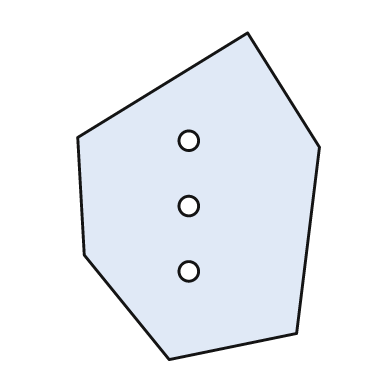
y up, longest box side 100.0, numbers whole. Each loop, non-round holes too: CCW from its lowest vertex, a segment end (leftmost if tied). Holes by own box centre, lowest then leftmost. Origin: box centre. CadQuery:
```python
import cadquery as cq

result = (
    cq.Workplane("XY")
    .moveTo(-9.0, -50.0)
    .lineTo(30.0, -42.0)
    .lineTo(37.0, 15.0)
    .lineTo(15.0, 50.0)
    .lineTo(-37.0, 18.0)
    .lineTo(-35.0, -18.0)
    .close()
    .moveTo(-3.0, -23.0)
    .circle(3.0)
    .moveTo(-3.0, -3.0)
    .circle(3.0)
    .moveTo(-3.0, 17.0)
    .circle(3.0)
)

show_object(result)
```